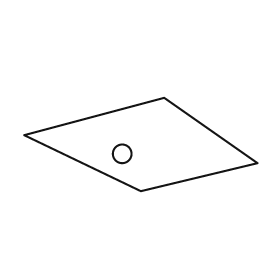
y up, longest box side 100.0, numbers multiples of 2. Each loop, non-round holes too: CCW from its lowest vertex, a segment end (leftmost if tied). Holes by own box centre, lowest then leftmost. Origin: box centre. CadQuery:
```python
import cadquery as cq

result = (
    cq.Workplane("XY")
    .moveTo(0.0, -20.0)
    .lineTo(50.0, -8.0)
    .lineTo(10.0, 20.0)
    .lineTo(-50.0, 4.0)
    .close()
    .moveTo(-8.0, -4.0)
    .circle(4.0)
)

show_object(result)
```